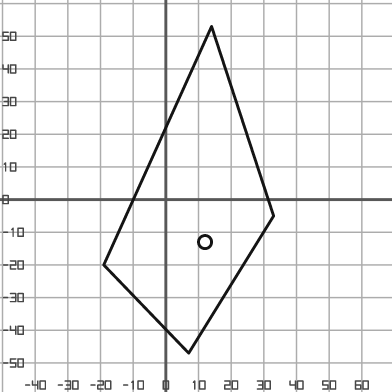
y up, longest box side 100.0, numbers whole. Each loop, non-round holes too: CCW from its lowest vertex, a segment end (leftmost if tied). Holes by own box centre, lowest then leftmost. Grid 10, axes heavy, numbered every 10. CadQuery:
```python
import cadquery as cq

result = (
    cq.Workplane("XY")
    .moveTo(7.0, -47.0)
    .lineTo(33.0, -5.0)
    .lineTo(14.0, 53.0)
    .lineTo(-19.0, -20.0)
    .close()
    .moveTo(12.0, -13.0)
    .circle(2.0)
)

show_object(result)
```